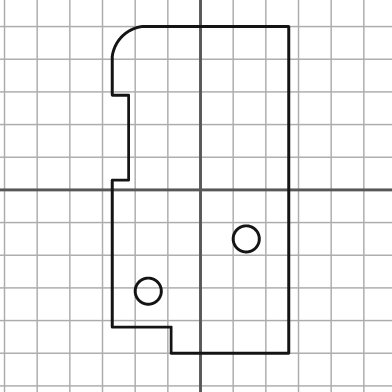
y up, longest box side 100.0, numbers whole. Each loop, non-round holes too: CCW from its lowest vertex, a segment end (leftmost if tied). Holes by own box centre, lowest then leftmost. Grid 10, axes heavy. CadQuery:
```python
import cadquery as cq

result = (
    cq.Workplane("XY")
    .moveTo(-9.0, -50.0)
    .lineTo(27.0, -50.0)
    .lineTo(27.0, 50.0)
    .lineTo(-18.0, 50.0)
    .threePointArc((-24.0, 47.0), (-27.0, 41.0))
    .lineTo(-27.0, 29.0)
    .lineTo(-22.0, 29.0)
    .lineTo(-22.0, 3.0)
    .lineTo(-27.0, 3.0)
    .lineTo(-27.0, -42.0)
    .lineTo(-9.0, -42.0)
    .close()
    .moveTo(-16.0, -31.0)
    .circle(4.0)
    .moveTo(14.0, -15.0)
    .circle(4.0)
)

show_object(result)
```